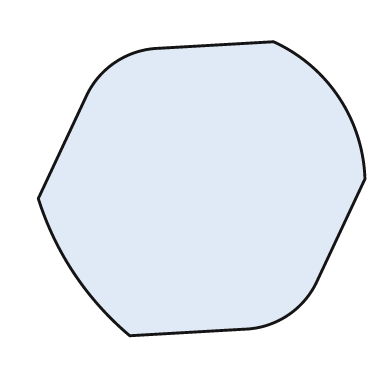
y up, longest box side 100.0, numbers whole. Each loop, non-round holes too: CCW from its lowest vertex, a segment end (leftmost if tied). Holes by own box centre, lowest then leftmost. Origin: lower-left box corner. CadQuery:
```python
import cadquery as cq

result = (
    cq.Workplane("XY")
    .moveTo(28.0, 0.0)
    .lineTo(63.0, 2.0)
    .threePointArc((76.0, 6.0), (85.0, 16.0))
    .lineTo(100.0, 48.0)
    .threePointArc((92.0, 73.0), (72.0, 90.0))
    .lineTo(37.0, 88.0)
    .threePointArc((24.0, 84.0), (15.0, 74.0))
    .lineTo(0.0, 42.0)
    .threePointArc((11.0, 19.0), (28.0, 0.0))
    .close()
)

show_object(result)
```